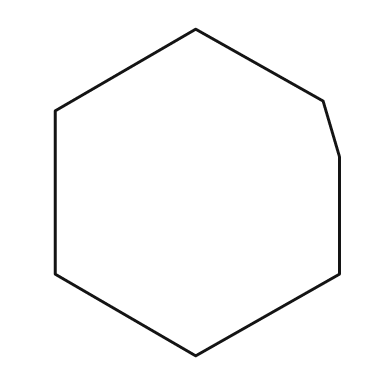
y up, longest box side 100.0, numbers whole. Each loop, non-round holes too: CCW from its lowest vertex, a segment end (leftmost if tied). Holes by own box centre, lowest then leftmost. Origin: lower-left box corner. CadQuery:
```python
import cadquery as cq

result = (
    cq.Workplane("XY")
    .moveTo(43.0, 0.0)
    .lineTo(87.0, 25.0)
    .lineTo(87.0, 61.0)
    .lineTo(82.0, 78.0)
    .lineTo(43.0, 100.0)
    .lineTo(0.0, 75.0)
    .lineTo(0.0, 25.0)
    .close()
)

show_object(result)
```